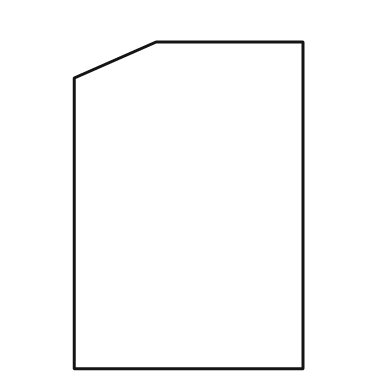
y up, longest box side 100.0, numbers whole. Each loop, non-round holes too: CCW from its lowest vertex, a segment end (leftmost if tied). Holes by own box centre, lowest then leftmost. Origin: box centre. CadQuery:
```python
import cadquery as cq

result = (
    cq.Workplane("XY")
    .moveTo(-35.0, -50.0)
    .lineTo(35.0, -50.0)
    .lineTo(35.0, 50.0)
    .lineTo(-10.0, 50.0)
    .lineTo(-35.0, 39.0)
    .close()
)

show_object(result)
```